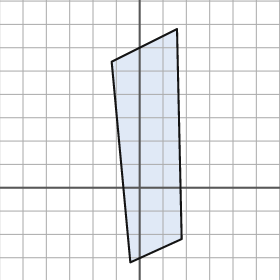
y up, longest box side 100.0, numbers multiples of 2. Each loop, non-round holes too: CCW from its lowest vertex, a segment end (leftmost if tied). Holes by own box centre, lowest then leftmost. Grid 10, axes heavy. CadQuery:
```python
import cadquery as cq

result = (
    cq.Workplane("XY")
    .moveTo(-4.0, -32.0)
    .lineTo(18.0, -22.0)
    .lineTo(16.0, 68.0)
    .lineTo(-12.0, 54.0)
    .close()
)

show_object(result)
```